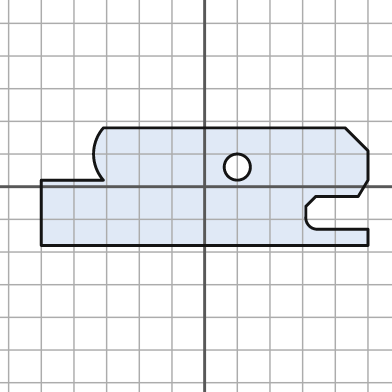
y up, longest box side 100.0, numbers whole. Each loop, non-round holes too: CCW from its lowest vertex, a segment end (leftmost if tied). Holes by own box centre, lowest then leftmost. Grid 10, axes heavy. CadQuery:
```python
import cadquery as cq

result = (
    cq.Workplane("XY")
    .moveTo(-50.0, -18.0)
    .lineTo(50.0, -18.0)
    .lineTo(50.0, -13.0)
    .lineTo(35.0, -13.0)
    .threePointArc((32.0, -12.0), (31.0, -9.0))
    .lineTo(31.0, -6.0)
    .lineTo(34.0, -3.0)
    .lineTo(47.0, -3.0)
    .lineTo(50.0, 2.0)
    .lineTo(50.0, 11.0)
    .lineTo(43.0, 18.0)
    .lineTo(-31.0, 18.0)
    .threePointArc((-34.0, 10.0), (-31.0, 2.0))
    .lineTo(-50.0, 2.0)
    .close()
    .moveTo(10.0, 6.0)
    .circle(4.0)
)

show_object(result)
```